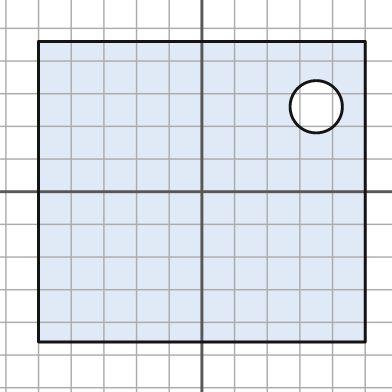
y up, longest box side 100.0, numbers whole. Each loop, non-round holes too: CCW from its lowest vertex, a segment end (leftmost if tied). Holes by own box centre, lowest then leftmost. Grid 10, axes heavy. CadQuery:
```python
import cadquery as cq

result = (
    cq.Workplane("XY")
    .moveTo(-50.0, -46.0)
    .lineTo(50.0, -46.0)
    .lineTo(50.0, 46.0)
    .lineTo(-50.0, 46.0)
    .close()
    .moveTo(35.0, 26.0)
    .circle(8.0)
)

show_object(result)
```